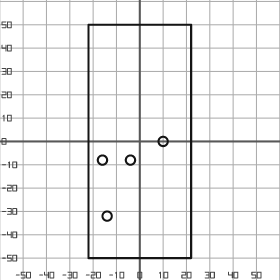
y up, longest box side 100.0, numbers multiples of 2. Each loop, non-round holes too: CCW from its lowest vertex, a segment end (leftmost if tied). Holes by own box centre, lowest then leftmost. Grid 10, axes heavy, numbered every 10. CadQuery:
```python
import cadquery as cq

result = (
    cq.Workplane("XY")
    .moveTo(-22.0, -50.0)
    .lineTo(22.0, -50.0)
    .lineTo(22.0, 50.0)
    .lineTo(-22.0, 50.0)
    .close()
    .moveTo(-14.0, -32.0)
    .circle(2.0)
    .moveTo(-16.0, -8.0)
    .circle(2.0)
    .moveTo(-4.0, -8.0)
    .circle(2.0)
    .moveTo(10.0, 0.0)
    .circle(2.0)
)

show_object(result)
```